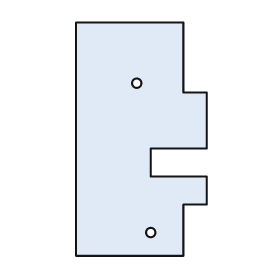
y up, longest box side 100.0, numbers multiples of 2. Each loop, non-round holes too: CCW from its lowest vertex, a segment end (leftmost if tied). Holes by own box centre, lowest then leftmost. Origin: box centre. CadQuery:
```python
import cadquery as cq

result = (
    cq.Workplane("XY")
    .moveTo(-28.0, -50.0)
    .lineTo(18.0, -50.0)
    .lineTo(18.0, -28.0)
    .lineTo(28.0, -28.0)
    .lineTo(28.0, -16.0)
    .lineTo(4.0, -16.0)
    .lineTo(4.0, -4.0)
    .lineTo(28.0, -4.0)
    .lineTo(28.0, 20.0)
    .lineTo(18.0, 20.0)
    .lineTo(18.0, 50.0)
    .lineTo(-28.0, 50.0)
    .close()
    .moveTo(4.0, -40.0)
    .circle(2.0)
    .moveTo(-2.0, 24.0)
    .circle(2.0)
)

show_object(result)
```